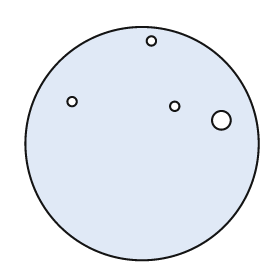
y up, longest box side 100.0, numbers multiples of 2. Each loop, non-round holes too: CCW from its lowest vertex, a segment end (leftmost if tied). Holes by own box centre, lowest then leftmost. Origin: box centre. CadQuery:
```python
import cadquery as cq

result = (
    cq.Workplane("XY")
    .moveTo(0.0, 0.0)
    .circle(50.0)
    .moveTo(34.0, 10.0)
    .circle(4.0)
    .moveTo(14.0, 16.0)
    .circle(2.0)
    .moveTo(-30.0, 18.0)
    .circle(2.0)
    .moveTo(4.0, 44.0)
    .circle(2.0)
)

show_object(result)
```